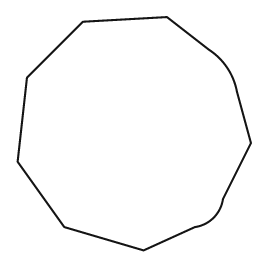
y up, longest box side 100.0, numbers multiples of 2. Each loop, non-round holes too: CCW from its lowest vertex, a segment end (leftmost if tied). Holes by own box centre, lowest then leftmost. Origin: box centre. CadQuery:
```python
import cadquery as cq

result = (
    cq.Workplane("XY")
    .moveTo(4.0, -50.0)
    .lineTo(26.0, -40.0)
    .threePointArc((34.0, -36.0), (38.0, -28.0))
    .lineTo(50.0, -4.0)
    .lineTo(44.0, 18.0)
    .threePointArc((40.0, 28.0), (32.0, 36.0))
    .lineTo(14.0, 50.0)
    .lineTo(-22.0, 48.0)
    .lineTo(-46.0, 24.0)
    .lineTo(-50.0, -12.0)
    .lineTo(-30.0, -40.0)
    .close()
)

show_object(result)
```